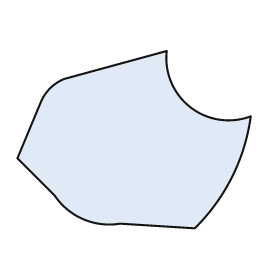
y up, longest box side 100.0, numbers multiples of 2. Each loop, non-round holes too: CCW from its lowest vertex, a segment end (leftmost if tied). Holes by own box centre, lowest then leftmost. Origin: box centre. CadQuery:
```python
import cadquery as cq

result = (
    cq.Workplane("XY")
    .moveTo(26.0, -38.0)
    .threePointArc((42.0, -16.0), (50.0, 10.0))
    .threePointArc((24.0, 14.0), (14.0, 38.0))
    .lineTo(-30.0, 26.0)
    .threePointArc((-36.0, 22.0), (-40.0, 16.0))
    .lineTo(-50.0, -8.0)
    .lineTo(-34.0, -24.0)
    .threePointArc((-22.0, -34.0), (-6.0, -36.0))
    .close()
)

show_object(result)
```